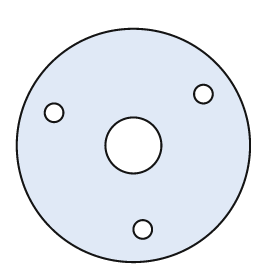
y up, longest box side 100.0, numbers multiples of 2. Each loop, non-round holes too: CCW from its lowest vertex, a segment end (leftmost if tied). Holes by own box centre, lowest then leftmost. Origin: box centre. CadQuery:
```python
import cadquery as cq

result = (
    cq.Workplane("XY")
    .moveTo(0.0, 0.0)
    .circle(50.0)
    .moveTo(4.0, -36.0)
    .circle(4.0)
    .moveTo(0.0, 0.0)
    .circle(12.0)
    .moveTo(-34.0, 14.0)
    .circle(4.0)
    .moveTo(30.0, 22.0)
    .circle(4.0)
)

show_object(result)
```